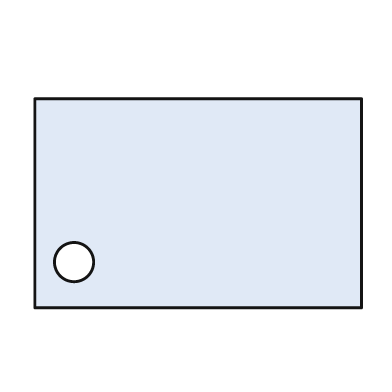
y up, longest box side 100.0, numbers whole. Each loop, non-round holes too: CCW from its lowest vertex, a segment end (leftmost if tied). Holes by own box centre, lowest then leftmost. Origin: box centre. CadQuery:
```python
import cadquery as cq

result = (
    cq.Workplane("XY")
    .moveTo(-50.0, -32.0)
    .lineTo(50.0, -32.0)
    .lineTo(50.0, 32.0)
    .lineTo(-50.0, 32.0)
    .close()
    .moveTo(-38.0, -18.0)
    .circle(6.0)
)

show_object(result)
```